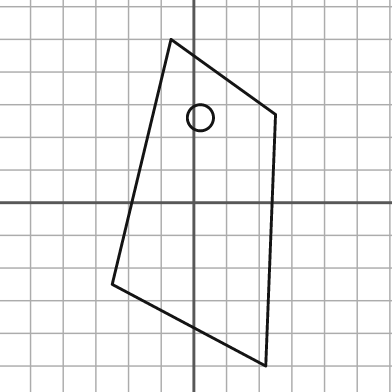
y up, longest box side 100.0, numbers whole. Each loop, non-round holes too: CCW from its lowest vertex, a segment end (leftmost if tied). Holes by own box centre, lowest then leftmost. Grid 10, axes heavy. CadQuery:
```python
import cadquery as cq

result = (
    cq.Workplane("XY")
    .moveTo(22.0, -50.0)
    .lineTo(25.0, 27.0)
    .lineTo(-7.0, 50.0)
    .lineTo(-25.0, -25.0)
    .close()
    .moveTo(2.0, 26.0)
    .circle(4.0)
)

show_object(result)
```